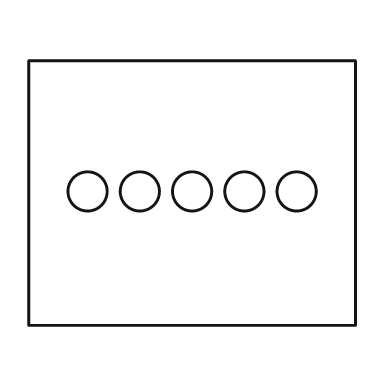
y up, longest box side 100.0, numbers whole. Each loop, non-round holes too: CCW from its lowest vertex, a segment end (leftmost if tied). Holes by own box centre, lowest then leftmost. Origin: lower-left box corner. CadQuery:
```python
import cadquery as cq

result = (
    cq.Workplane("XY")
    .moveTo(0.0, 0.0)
    .lineTo(100.0, 0.0)
    .lineTo(100.0, 81.0)
    .lineTo(0.0, 81.0)
    .close()
    .moveTo(18.0, 41.0)
    .circle(6.0)
    .moveTo(34.0, 41.0)
    .circle(6.0)
    .moveTo(50.0, 41.0)
    .circle(6.0)
    .moveTo(66.0, 41.0)
    .circle(6.0)
    .moveTo(82.0, 41.0)
    .circle(6.0)
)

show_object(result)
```